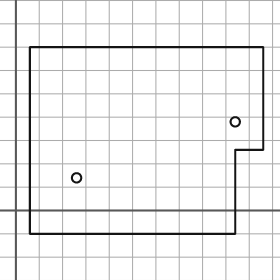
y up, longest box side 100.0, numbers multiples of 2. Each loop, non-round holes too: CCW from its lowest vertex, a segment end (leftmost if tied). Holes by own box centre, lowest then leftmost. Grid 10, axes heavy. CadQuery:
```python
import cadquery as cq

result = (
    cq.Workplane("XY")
    .moveTo(6.0, -10.0)
    .lineTo(94.0, -10.0)
    .lineTo(94.0, 26.0)
    .lineTo(106.0, 26.0)
    .lineTo(106.0, 70.0)
    .lineTo(6.0, 70.0)
    .close()
    .moveTo(26.0, 14.0)
    .circle(2.0)
    .moveTo(94.0, 38.0)
    .circle(2.0)
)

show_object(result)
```